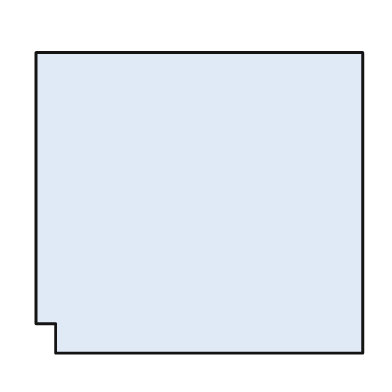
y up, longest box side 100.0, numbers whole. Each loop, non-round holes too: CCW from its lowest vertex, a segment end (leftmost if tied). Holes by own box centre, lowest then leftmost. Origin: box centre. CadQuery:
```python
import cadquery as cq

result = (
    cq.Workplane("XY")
    .moveTo(-44.0, -46.0)
    .lineTo(50.0, -46.0)
    .lineTo(50.0, 46.0)
    .lineTo(-50.0, 46.0)
    .lineTo(-50.0, -37.0)
    .lineTo(-44.0, -37.0)
    .close()
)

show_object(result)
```